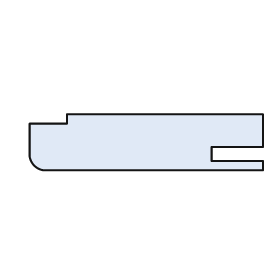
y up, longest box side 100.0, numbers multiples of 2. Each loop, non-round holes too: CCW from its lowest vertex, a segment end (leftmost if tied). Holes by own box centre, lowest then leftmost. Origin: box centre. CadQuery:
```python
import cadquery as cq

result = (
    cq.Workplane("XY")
    .moveTo(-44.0, -12.0)
    .lineTo(50.0, -12.0)
    .lineTo(50.0, -8.0)
    .lineTo(28.0, -8.0)
    .lineTo(28.0, -2.0)
    .lineTo(50.0, -2.0)
    .lineTo(50.0, 12.0)
    .lineTo(-34.0, 12.0)
    .lineTo(-34.0, 8.0)
    .lineTo(-50.0, 8.0)
    .lineTo(-50.0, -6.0)
    .threePointArc((-48.0, -10.0), (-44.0, -12.0))
    .close()
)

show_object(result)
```